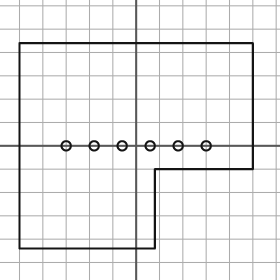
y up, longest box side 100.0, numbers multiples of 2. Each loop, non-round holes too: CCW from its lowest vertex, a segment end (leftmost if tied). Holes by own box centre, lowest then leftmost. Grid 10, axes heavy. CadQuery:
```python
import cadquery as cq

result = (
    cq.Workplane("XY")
    .moveTo(-50.0, -44.0)
    .lineTo(8.0, -44.0)
    .lineTo(8.0, -10.0)
    .lineTo(50.0, -10.0)
    .lineTo(50.0, 44.0)
    .lineTo(-50.0, 44.0)
    .close()
    .moveTo(-30.0, 0.0)
    .circle(2.0)
    .moveTo(-18.0, 0.0)
    .circle(2.0)
    .moveTo(-6.0, 0.0)
    .circle(2.0)
    .moveTo(6.0, 0.0)
    .circle(2.0)
    .moveTo(18.0, 0.0)
    .circle(2.0)
    .moveTo(30.0, 0.0)
    .circle(2.0)
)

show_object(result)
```